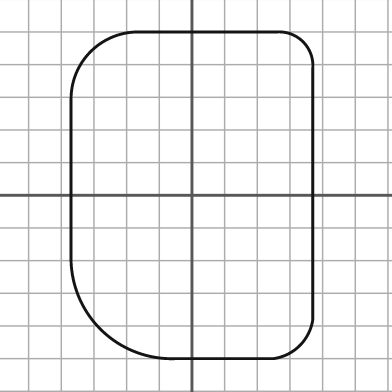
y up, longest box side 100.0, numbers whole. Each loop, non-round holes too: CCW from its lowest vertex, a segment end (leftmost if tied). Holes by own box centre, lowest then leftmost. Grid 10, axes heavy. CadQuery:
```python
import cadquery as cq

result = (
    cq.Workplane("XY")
    .moveTo(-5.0, -50.0)
    .lineTo(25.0, -50.0)
    .threePointArc((33.0, -46.0), (37.0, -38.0))
    .lineTo(37.0, 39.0)
    .threePointArc((34.0, 47.0), (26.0, 50.0))
    .lineTo(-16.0, 50.0)
    .threePointArc((-31.0, 44.0), (-37.0, 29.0))
    .lineTo(-37.0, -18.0)
    .threePointArc((-28.0, -41.0), (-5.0, -50.0))
    .close()
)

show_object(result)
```